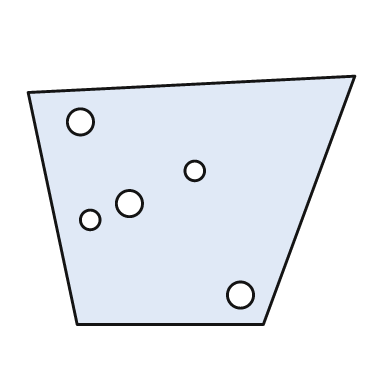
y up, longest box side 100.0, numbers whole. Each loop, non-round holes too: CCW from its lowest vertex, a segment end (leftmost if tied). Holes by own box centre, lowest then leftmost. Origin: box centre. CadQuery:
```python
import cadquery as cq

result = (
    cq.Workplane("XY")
    .moveTo(-35.0, -38.0)
    .lineTo(22.0, -38.0)
    .lineTo(50.0, 38.0)
    .lineTo(-50.0, 33.0)
    .close()
    .moveTo(15.0, -29.0)
    .circle(4.0)
    .moveTo(-31.0, -6.0)
    .circle(3.0)
    .moveTo(-19.0, -1.0)
    .circle(4.0)
    .moveTo(1.0, 9.0)
    .circle(3.0)
    .moveTo(-34.0, 24.0)
    .circle(4.0)
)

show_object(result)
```